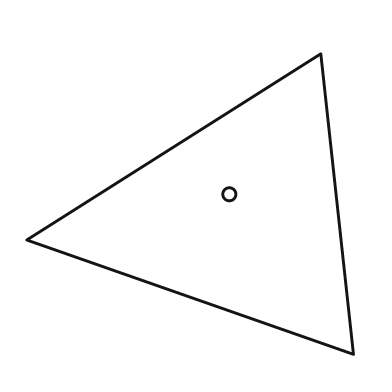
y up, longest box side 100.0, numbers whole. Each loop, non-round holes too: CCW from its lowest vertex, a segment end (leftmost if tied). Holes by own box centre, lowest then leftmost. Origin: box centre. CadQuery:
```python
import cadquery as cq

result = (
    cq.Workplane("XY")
    .moveTo(50.0, -46.0)
    .lineTo(40.0, 46.0)
    .lineTo(-50.0, -11.0)
    .close()
    .moveTo(12.0, 3.0)
    .circle(2.0)
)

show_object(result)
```